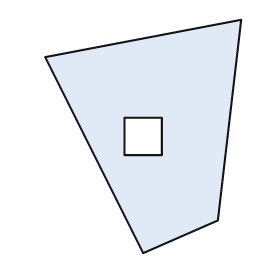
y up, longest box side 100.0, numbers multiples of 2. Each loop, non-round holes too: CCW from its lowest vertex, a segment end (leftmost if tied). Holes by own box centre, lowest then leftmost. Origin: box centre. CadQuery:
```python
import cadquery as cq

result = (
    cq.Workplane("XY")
    .moveTo(0.0, -50.0)
    .lineTo(32.0, -36.0)
    .lineTo(42.0, 50.0)
    .lineTo(-42.0, 34.0)
    .close()
    .moveTo(-8.0, -8.0)
    .lineTo(8.0, -8.0)
    .lineTo(8.0, 8.0)
    .lineTo(-8.0, 8.0)
    .close()
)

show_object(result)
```